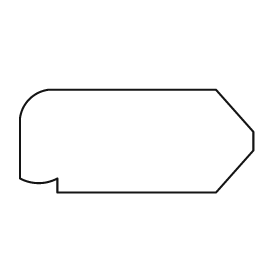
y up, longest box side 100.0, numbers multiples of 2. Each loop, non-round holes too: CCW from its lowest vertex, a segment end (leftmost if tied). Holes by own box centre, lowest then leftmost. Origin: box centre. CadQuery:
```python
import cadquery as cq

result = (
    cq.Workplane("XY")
    .moveTo(-34.0, -22.0)
    .lineTo(34.0, -22.0)
    .lineTo(50.0, -4.0)
    .lineTo(50.0, 4.0)
    .lineTo(34.0, 22.0)
    .lineTo(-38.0, 22.0)
    .threePointArc((-46.0, 18.0), (-50.0, 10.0))
    .lineTo(-50.0, -16.0)
    .threePointArc((-42.0, -18.0), (-34.0, -16.0))
    .close()
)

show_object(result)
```